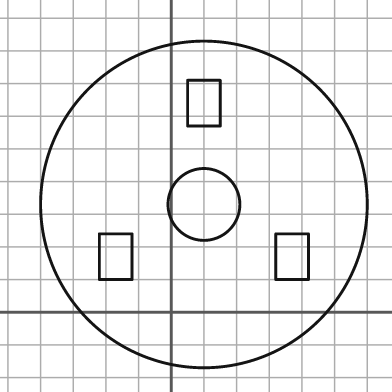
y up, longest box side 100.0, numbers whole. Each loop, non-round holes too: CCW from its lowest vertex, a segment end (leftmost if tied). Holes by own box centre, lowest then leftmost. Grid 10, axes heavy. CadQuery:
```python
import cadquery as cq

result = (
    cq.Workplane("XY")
    .moveTo(10.0, 33.0)
    .circle(50.0)
    .moveTo(-22.0, 10.0)
    .lineTo(-12.0, 10.0)
    .lineTo(-12.0, 24.0)
    .lineTo(-22.0, 24.0)
    .close()
    .moveTo(32.0, 10.0)
    .lineTo(42.0, 10.0)
    .lineTo(42.0, 24.0)
    .lineTo(32.0, 24.0)
    .close()
    .moveTo(10.0, 33.0)
    .circle(11.0)
    .moveTo(5.0, 57.0)
    .lineTo(15.0, 57.0)
    .lineTo(15.0, 71.0)
    .lineTo(5.0, 71.0)
    .close()
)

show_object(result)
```